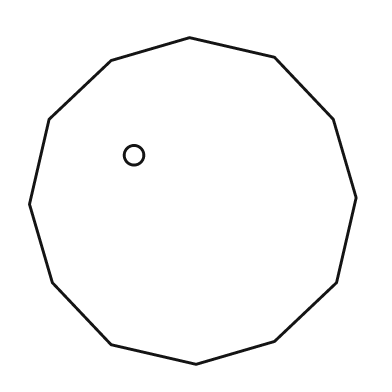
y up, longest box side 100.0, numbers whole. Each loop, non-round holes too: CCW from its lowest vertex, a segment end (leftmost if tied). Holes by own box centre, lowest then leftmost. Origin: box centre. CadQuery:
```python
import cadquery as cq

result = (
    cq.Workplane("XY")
    .moveTo(1.0, -50.0)
    .lineTo(25.0, -43.0)
    .lineTo(44.0, -25.0)
    .lineTo(50.0, 1.0)
    .lineTo(43.0, 25.0)
    .lineTo(25.0, 44.0)
    .lineTo(-1.0, 50.0)
    .lineTo(-25.0, 43.0)
    .lineTo(-44.0, 25.0)
    .lineTo(-50.0, -1.0)
    .lineTo(-43.0, -25.0)
    .lineTo(-25.0, -44.0)
    .close()
    .moveTo(-18.0, 14.0)
    .circle(3.0)
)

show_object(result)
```